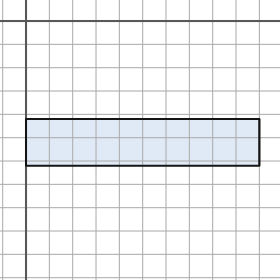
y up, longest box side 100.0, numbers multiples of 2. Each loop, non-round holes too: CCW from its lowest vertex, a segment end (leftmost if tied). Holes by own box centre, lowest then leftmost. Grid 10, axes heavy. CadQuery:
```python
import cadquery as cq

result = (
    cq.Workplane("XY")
    .moveTo(0.0, -62.0)
    .lineTo(100.0, -62.0)
    .lineTo(100.0, -42.0)
    .lineTo(0.0, -42.0)
    .close()
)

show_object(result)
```